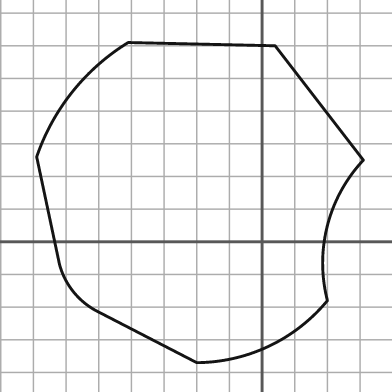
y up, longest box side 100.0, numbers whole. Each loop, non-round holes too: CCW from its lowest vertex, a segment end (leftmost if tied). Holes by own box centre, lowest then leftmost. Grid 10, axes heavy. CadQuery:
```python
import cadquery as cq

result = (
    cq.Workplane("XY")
    .moveTo(-20.0, -37.0)
    .threePointArc((2.0, -32.0), (20.0, -18.0))
    .threePointArc((20.0, 5.0), (31.0, 25.0))
    .lineTo(4.0, 60.0)
    .lineTo(-41.0, 61.0)
    .threePointArc((-58.0, 46.0), (-69.0, 26.0))
    .lineTo(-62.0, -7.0)
    .threePointArc((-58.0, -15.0), (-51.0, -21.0))
    .close()
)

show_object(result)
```